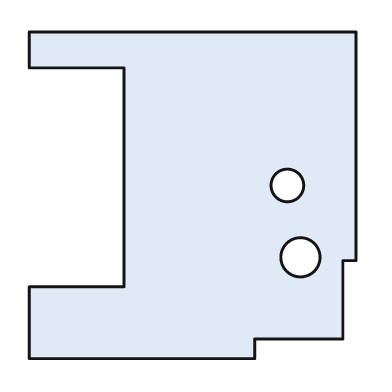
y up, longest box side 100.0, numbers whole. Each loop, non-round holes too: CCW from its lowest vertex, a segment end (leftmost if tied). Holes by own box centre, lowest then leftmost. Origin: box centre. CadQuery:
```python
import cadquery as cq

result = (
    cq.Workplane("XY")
    .moveTo(-50.0, -50.0)
    .lineTo(19.0, -50.0)
    .lineTo(19.0, -44.0)
    .lineTo(46.0, -44.0)
    .lineTo(46.0, -20.0)
    .lineTo(50.0, -20.0)
    .lineTo(50.0, 50.0)
    .lineTo(-50.0, 50.0)
    .lineTo(-50.0, 39.0)
    .lineTo(-21.0, 39.0)
    .lineTo(-21.0, -28.0)
    .lineTo(-50.0, -28.0)
    .close()
    .moveTo(33.0, -19.0)
    .circle(6.0)
    .moveTo(29.0, 3.0)
    .circle(5.0)
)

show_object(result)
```